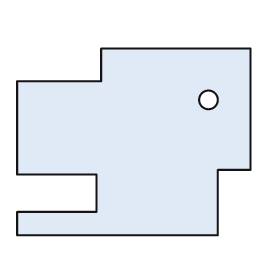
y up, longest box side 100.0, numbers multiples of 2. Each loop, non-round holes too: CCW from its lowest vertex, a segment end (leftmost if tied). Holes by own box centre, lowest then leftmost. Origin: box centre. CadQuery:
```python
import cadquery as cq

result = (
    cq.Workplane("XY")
    .moveTo(-50.0, -40.0)
    .lineTo(36.0, -40.0)
    .lineTo(36.0, -12.0)
    .lineTo(50.0, -12.0)
    .lineTo(50.0, 40.0)
    .lineTo(-14.0, 40.0)
    .lineTo(-14.0, 26.0)
    .lineTo(-50.0, 26.0)
    .lineTo(-50.0, -14.0)
    .lineTo(-16.0, -14.0)
    .lineTo(-16.0, -30.0)
    .lineTo(-50.0, -30.0)
    .close()
    .moveTo(32.0, 18.0)
    .circle(4.0)
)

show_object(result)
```